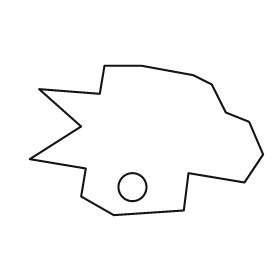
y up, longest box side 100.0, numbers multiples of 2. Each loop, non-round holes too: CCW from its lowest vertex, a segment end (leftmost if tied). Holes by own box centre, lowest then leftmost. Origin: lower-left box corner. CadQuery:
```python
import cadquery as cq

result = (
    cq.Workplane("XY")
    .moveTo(36.0, 0.0)
    .lineTo(66.0, 2.0)
    .lineTo(68.0, 18.0)
    .lineTo(92.0, 14.0)
    .lineTo(100.0, 26.0)
    .lineTo(94.0, 40.0)
    .lineTo(84.0, 44.0)
    .lineTo(78.0, 56.0)
    .lineTo(70.0, 60.0)
    .lineTo(48.0, 64.0)
    .lineTo(32.0, 64.0)
    .lineTo(30.0, 52.0)
    .lineTo(4.0, 54.0)
    .lineTo(22.0, 38.0)
    .lineTo(0.0, 24.0)
    .lineTo(24.0, 20.0)
    .lineTo(22.0, 8.0)
    .close()
    .moveTo(44.0, 12.0)
    .circle(6.0)
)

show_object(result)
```